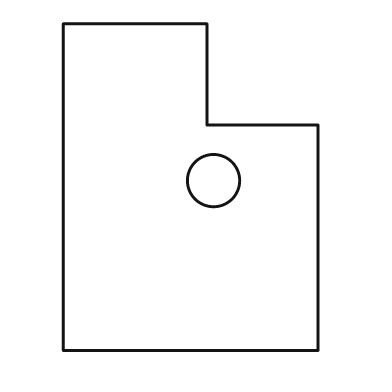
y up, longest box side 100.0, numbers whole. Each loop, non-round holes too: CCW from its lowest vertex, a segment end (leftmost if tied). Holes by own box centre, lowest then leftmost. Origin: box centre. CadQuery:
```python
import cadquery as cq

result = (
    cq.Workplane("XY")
    .moveTo(-39.0, -50.0)
    .lineTo(39.0, -50.0)
    .lineTo(39.0, 19.0)
    .lineTo(5.0, 19.0)
    .lineTo(5.0, 50.0)
    .lineTo(-39.0, 50.0)
    .close()
    .moveTo(7.0, 2.0)
    .circle(8.0)
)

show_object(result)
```